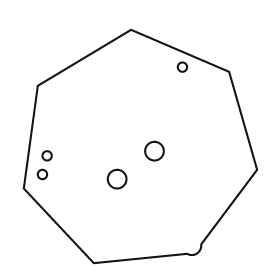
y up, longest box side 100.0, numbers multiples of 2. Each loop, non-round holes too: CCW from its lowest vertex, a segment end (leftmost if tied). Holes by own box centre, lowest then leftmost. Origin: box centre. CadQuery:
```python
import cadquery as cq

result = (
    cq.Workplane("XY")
    .moveTo(-20.0, -50.0)
    .lineTo(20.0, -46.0)
    .threePointArc((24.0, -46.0), (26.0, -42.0))
    .lineTo(50.0, -10.0)
    .lineTo(38.0, 32.0)
    .lineTo(-4.0, 50.0)
    .lineTo(-44.0, 26.0)
    .lineTo(-50.0, -18.0)
    .close()
    .moveTo(-10.0, -14.0)
    .circle(4.0)
    .moveTo(-42.0, -12.0)
    .circle(2.0)
    .moveTo(-40.0, -4.0)
    .circle(2.0)
    .moveTo(6.0, -2.0)
    .circle(4.0)
    .moveTo(18.0, 34.0)
    .circle(2.0)
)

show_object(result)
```